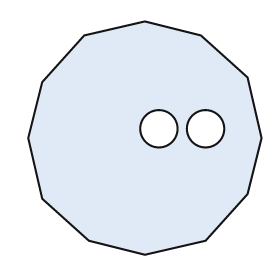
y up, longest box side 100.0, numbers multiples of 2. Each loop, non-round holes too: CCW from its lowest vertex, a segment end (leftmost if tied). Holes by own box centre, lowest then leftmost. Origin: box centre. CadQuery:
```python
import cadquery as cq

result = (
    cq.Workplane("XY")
    .moveTo(0.0, -50.0)
    .lineTo(26.0, -44.0)
    .lineTo(44.0, -24.0)
    .lineTo(50.0, 0.0)
    .lineTo(44.0, 26.0)
    .lineTo(24.0, 44.0)
    .lineTo(0.0, 50.0)
    .lineTo(-26.0, 44.0)
    .lineTo(-44.0, 24.0)
    .lineTo(-50.0, 0.0)
    .lineTo(-44.0, -26.0)
    .lineTo(-24.0, -44.0)
    .close()
    .moveTo(6.0, 4.0)
    .circle(8.0)
    .moveTo(26.0, 4.0)
    .circle(8.0)
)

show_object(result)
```